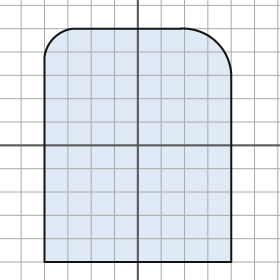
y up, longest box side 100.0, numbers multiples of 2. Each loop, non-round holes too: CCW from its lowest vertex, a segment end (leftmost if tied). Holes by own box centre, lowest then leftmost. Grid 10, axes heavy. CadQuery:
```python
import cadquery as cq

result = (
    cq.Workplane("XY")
    .moveTo(-40.0, -50.0)
    .lineTo(40.0, -50.0)
    .lineTo(40.0, 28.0)
    .threePointArc((34.0, 44.0), (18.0, 50.0))
    .lineTo(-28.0, 50.0)
    .threePointArc((-36.0, 46.0), (-40.0, 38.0))
    .close()
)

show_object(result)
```